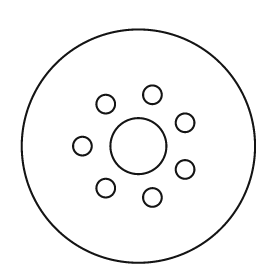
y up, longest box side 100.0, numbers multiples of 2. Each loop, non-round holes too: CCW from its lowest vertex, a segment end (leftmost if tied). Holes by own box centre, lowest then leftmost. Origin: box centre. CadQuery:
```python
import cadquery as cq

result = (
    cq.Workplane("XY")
    .moveTo(0.0, 0.0)
    .circle(50.0)
    .moveTo(6.0, -22.0)
    .circle(4.0)
    .moveTo(-14.0, -18.0)
    .circle(4.0)
    .moveTo(20.0, -10.0)
    .circle(4.0)
    .moveTo(-24.0, 0.0)
    .circle(4.0)
    .moveTo(0.0, 0.0)
    .circle(12.0)
    .moveTo(20.0, 10.0)
    .circle(4.0)
    .moveTo(-14.0, 18.0)
    .circle(4.0)
    .moveTo(6.0, 22.0)
    .circle(4.0)
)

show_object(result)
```